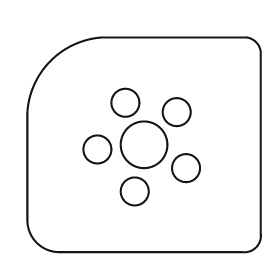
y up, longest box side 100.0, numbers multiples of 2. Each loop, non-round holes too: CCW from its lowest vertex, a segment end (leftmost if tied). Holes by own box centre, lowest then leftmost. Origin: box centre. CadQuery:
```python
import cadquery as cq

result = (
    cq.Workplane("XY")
    .moveTo(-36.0, -46.0)
    .lineTo(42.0, -46.0)
    .threePointArc((48.0, -44.0), (50.0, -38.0))
    .lineTo(50.0, 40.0)
    .threePointArc((48.0, 44.0), (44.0, 46.0))
    .lineTo(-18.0, 46.0)
    .threePointArc((-40.0, 36.0), (-50.0, 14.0))
    .lineTo(-50.0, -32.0)
    .threePointArc((-46.0, -42.0), (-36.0, -46.0))
    .close()
    .moveTo(-4.0, -20.0)
    .circle(6.0)
    .moveTo(18.0, -10.0)
    .circle(6.0)
    .moveTo(-20.0, -2.0)
    .circle(6.0)
    .moveTo(0.0, 0.0)
    .circle(10.0)
    .moveTo(14.0, 14.0)
    .circle(6.0)
    .moveTo(-8.0, 18.0)
    .circle(6.0)
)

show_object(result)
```